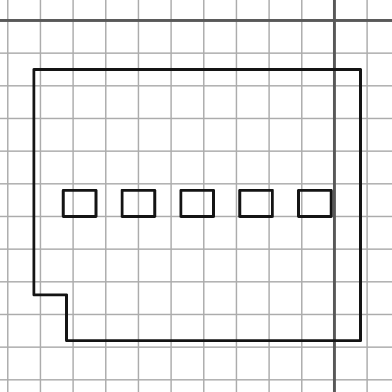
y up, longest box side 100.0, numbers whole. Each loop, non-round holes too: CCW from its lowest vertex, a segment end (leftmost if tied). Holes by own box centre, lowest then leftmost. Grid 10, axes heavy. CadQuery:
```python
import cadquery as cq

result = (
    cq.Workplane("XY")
    .moveTo(-82.0, -98.0)
    .lineTo(8.0, -98.0)
    .lineTo(8.0, -15.0)
    .lineTo(-92.0, -15.0)
    .lineTo(-92.0, -84.0)
    .lineTo(-82.0, -84.0)
    .close()
    .moveTo(-83.0, -60.0)
    .lineTo(-73.0, -60.0)
    .lineTo(-73.0, -52.0)
    .lineTo(-83.0, -52.0)
    .close()
    .moveTo(-65.0, -60.0)
    .lineTo(-55.0, -60.0)
    .lineTo(-55.0, -52.0)
    .lineTo(-65.0, -52.0)
    .close()
    .moveTo(-47.0, -60.0)
    .lineTo(-37.0, -60.0)
    .lineTo(-37.0, -52.0)
    .lineTo(-47.0, -52.0)
    .close()
    .moveTo(-29.0, -60.0)
    .lineTo(-19.0, -60.0)
    .lineTo(-19.0, -52.0)
    .lineTo(-29.0, -52.0)
    .close()
    .moveTo(-11.0, -60.0)
    .lineTo(-1.0, -60.0)
    .lineTo(-1.0, -52.0)
    .lineTo(-11.0, -52.0)
    .close()
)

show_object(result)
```